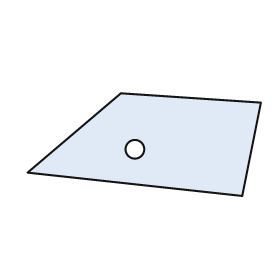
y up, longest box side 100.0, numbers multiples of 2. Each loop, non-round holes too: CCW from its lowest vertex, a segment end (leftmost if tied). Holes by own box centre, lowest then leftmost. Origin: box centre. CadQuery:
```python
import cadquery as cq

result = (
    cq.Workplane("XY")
    .moveTo(42.0, -22.0)
    .lineTo(50.0, 18.0)
    .lineTo(-10.0, 22.0)
    .lineTo(-50.0, -12.0)
    .close()
    .moveTo(-4.0, -2.0)
    .circle(4.0)
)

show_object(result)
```